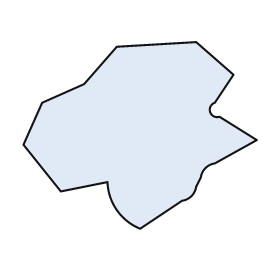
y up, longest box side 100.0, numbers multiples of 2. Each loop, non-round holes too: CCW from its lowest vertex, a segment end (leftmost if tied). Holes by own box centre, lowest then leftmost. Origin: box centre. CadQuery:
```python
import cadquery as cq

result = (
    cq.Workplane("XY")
    .moveTo(0.0, -40.0)
    .lineTo(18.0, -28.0)
    .threePointArc((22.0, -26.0), (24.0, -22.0))
    .lineTo(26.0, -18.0)
    .threePointArc((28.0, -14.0), (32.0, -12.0))
    .lineTo(50.0, -2.0)
    .lineTo(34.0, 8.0)
    .threePointArc((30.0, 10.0), (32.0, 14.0))
    .lineTo(40.0, 26.0)
    .lineTo(24.0, 40.0)
    .lineTo(-10.0, 38.0)
    .lineTo(-24.0, 22.0)
    .lineTo(-42.0, 14.0)
    .lineTo(-50.0, -4.0)
    .lineTo(-34.0, -24.0)
    .lineTo(-14.0, -20.0)
    .threePointArc((-10.0, -32.0), (0.0, -40.0))
    .close()
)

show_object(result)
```